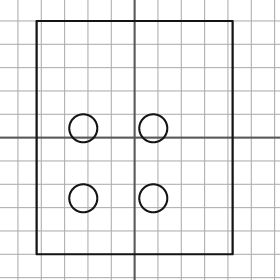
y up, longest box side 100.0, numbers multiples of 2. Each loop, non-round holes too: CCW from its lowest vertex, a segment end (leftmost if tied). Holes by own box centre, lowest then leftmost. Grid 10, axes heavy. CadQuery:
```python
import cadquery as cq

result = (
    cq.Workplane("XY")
    .moveTo(-42.0, -50.0)
    .lineTo(42.0, -50.0)
    .lineTo(42.0, 50.0)
    .lineTo(-42.0, 50.0)
    .close()
    .moveTo(-22.0, -26.0)
    .circle(6.0)
    .moveTo(8.0, -26.0)
    .circle(6.0)
    .moveTo(-22.0, 4.0)
    .circle(6.0)
    .moveTo(8.0, 4.0)
    .circle(6.0)
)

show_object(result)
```